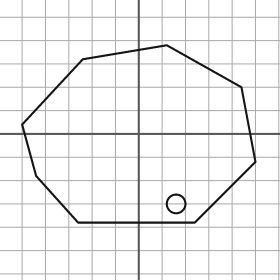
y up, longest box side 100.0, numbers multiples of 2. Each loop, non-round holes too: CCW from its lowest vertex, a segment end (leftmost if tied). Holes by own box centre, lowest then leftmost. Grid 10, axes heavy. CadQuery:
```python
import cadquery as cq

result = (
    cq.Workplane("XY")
    .moveTo(-26.0, -38.0)
    .lineTo(24.0, -38.0)
    .lineTo(50.0, -12.0)
    .lineTo(44.0, 20.0)
    .lineTo(12.0, 38.0)
    .lineTo(-24.0, 32.0)
    .lineTo(-50.0, 4.0)
    .lineTo(-44.0, -18.0)
    .close()
    .moveTo(16.0, -30.0)
    .circle(4.0)
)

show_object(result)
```